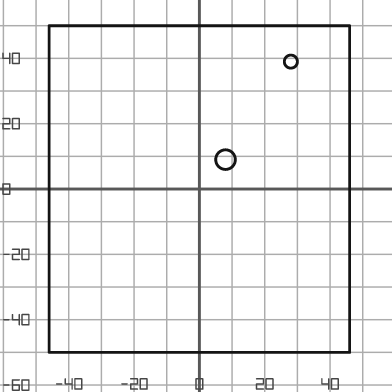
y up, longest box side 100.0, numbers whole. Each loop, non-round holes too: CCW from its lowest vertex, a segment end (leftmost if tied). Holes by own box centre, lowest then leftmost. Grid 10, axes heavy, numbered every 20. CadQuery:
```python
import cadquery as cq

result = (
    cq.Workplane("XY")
    .moveTo(-46.0, -50.0)
    .lineTo(46.0, -50.0)
    .lineTo(46.0, 50.0)
    .lineTo(-46.0, 50.0)
    .close()
    .moveTo(8.0, 9.0)
    .circle(3.0)
    .moveTo(28.0, 39.0)
    .circle(2.0)
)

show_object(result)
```